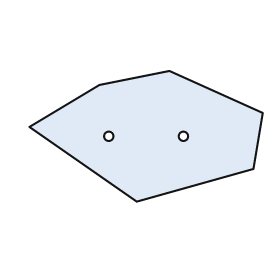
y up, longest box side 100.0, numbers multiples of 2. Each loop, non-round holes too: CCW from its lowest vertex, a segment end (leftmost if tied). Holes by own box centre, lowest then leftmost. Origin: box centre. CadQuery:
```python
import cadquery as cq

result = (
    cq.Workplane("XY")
    .moveTo(-4.0, -28.0)
    .lineTo(46.0, -14.0)
    .lineTo(50.0, 10.0)
    .lineTo(10.0, 28.0)
    .lineTo(-20.0, 22.0)
    .lineTo(-50.0, 4.0)
    .close()
    .moveTo(-16.0, 0.0)
    .circle(2.0)
    .moveTo(16.0, 0.0)
    .circle(2.0)
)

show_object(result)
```